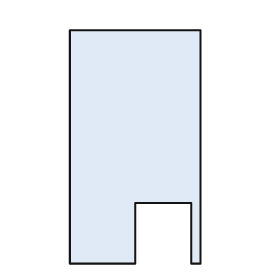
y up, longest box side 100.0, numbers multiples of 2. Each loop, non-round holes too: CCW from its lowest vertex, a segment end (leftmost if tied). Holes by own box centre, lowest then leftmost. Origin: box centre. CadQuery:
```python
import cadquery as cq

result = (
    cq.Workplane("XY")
    .moveTo(-28.0, -50.0)
    .lineTo(0.0, -50.0)
    .lineTo(0.0, -24.0)
    .lineTo(24.0, -24.0)
    .lineTo(24.0, -50.0)
    .lineTo(28.0, -50.0)
    .lineTo(28.0, 50.0)
    .lineTo(-28.0, 50.0)
    .close()
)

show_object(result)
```